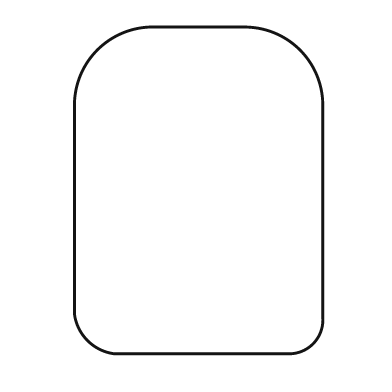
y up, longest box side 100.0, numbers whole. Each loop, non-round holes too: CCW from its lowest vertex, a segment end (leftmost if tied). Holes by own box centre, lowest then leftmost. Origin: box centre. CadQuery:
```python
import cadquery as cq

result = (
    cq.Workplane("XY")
    .moveTo(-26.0, -50.0)
    .lineTo(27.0, -50.0)
    .threePointArc((35.0, -47.0), (38.0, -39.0))
    .lineTo(38.0, 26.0)
    .threePointArc((31.0, 43.0), (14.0, 50.0))
    .lineTo(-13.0, 50.0)
    .threePointArc((-31.0, 43.0), (-38.0, 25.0))
    .lineTo(-38.0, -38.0)
    .threePointArc((-34.0, -46.0), (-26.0, -50.0))
    .close()
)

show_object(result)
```